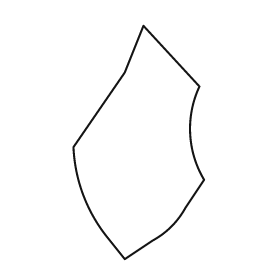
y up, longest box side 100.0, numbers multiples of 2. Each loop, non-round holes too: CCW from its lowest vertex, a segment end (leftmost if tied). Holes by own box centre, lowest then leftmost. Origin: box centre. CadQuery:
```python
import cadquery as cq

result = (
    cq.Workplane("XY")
    .moveTo(-6.0, -50.0)
    .lineTo(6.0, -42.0)
    .threePointArc((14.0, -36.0), (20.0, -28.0))
    .lineTo(28.0, -16.0)
    .threePointArc((22.0, 4.0), (26.0, 24.0))
    .lineTo(2.0, 50.0)
    .lineTo(-6.0, 30.0)
    .lineTo(-28.0, -2.0)
    .threePointArc((-24.0, -22.0), (-14.0, -40.0))
    .close()
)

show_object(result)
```